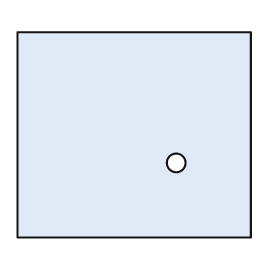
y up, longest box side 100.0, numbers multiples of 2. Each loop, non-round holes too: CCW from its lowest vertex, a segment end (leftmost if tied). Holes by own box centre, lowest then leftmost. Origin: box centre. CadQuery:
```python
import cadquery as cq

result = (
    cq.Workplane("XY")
    .moveTo(-50.0, -44.0)
    .lineTo(50.0, -44.0)
    .lineTo(50.0, 44.0)
    .lineTo(-50.0, 44.0)
    .close()
    .moveTo(18.0, -12.0)
    .circle(4.0)
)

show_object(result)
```